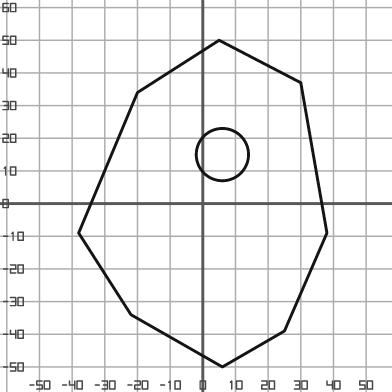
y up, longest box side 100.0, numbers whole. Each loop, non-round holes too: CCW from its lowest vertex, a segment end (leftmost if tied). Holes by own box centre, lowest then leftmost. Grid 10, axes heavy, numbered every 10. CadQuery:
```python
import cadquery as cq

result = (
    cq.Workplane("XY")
    .moveTo(6.0, -50.0)
    .lineTo(25.0, -39.0)
    .lineTo(38.0, -9.0)
    .lineTo(30.0, 37.0)
    .lineTo(5.0, 50.0)
    .lineTo(-20.0, 34.0)
    .lineTo(-38.0, -9.0)
    .lineTo(-22.0, -34.0)
    .close()
    .moveTo(6.0, 15.0)
    .circle(8.0)
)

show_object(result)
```